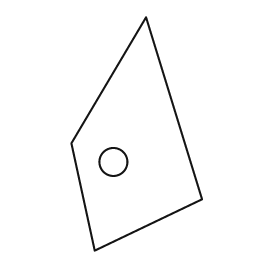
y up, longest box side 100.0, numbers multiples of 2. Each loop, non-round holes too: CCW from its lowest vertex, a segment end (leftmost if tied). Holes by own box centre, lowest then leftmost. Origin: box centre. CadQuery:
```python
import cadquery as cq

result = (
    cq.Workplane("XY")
    .moveTo(-18.0, -50.0)
    .lineTo(28.0, -28.0)
    .lineTo(4.0, 50.0)
    .lineTo(-28.0, -4.0)
    .close()
    .moveTo(-10.0, -12.0)
    .circle(6.0)
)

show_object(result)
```